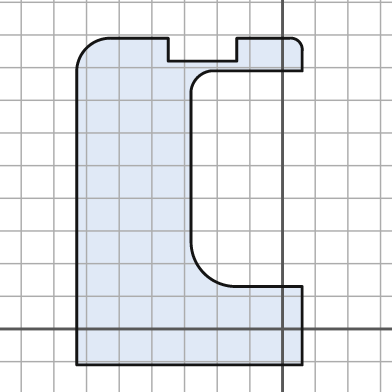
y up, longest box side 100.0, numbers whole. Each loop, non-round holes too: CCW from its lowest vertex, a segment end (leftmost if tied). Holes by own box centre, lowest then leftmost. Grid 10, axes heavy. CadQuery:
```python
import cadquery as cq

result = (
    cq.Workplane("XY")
    .moveTo(-63.0, -11.0)
    .lineTo(6.0, -11.0)
    .lineTo(6.0, 13.0)
    .lineTo(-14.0, 13.0)
    .threePointArc((-24.0, 17.0), (-28.0, 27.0))
    .lineTo(-28.0, 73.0)
    .threePointArc((-26.0, 77.0), (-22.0, 79.0))
    .lineTo(6.0, 79.0)
    .lineTo(6.0, 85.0)
    .threePointArc((5.0, 88.0), (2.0, 89.0))
    .lineTo(-14.0, 89.0)
    .lineTo(-14.0, 82.0)
    .lineTo(-35.0, 82.0)
    .lineTo(-35.0, 89.0)
    .lineTo(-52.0, 89.0)
    .threePointArc((-60.0, 86.0), (-63.0, 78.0))
    .close()
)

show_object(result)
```